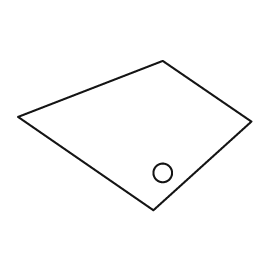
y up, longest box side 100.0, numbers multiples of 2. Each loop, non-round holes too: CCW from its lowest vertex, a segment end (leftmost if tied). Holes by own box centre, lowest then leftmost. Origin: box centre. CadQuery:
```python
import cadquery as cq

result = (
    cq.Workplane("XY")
    .moveTo(8.0, -32.0)
    .lineTo(50.0, 6.0)
    .lineTo(12.0, 32.0)
    .lineTo(-50.0, 8.0)
    .close()
    .moveTo(12.0, -16.0)
    .circle(4.0)
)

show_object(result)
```